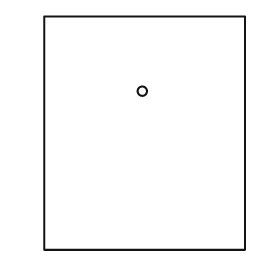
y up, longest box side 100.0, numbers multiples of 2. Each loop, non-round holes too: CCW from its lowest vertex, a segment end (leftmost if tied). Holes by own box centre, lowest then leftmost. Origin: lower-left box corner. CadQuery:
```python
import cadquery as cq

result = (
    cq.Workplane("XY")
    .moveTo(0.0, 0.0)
    .lineTo(86.0, 0.0)
    .lineTo(86.0, 100.0)
    .lineTo(0.0, 100.0)
    .close()
    .moveTo(42.0, 68.0)
    .circle(2.0)
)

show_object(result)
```